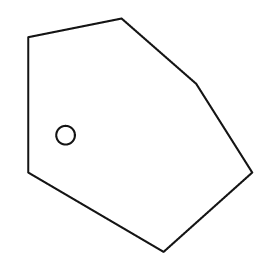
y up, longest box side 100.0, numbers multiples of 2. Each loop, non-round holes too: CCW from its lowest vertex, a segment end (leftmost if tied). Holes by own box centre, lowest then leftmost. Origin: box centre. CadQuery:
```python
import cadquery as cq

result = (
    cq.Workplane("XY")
    .moveTo(10.0, -50.0)
    .lineTo(48.0, -16.0)
    .lineTo(24.0, 22.0)
    .lineTo(-8.0, 50.0)
    .lineTo(-48.0, 42.0)
    .lineTo(-48.0, -16.0)
    .close()
    .moveTo(-32.0, 0.0)
    .circle(4.0)
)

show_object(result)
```